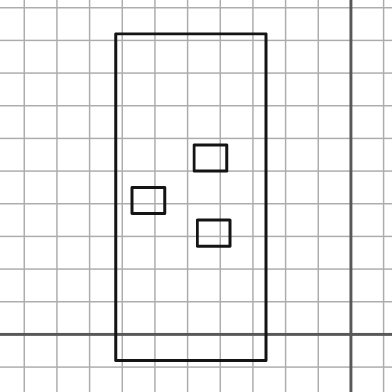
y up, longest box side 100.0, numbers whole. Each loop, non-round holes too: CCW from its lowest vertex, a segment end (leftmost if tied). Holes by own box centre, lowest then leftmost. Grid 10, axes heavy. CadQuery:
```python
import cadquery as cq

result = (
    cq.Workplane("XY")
    .moveTo(-72.0, -8.0)
    .lineTo(-26.0, -8.0)
    .lineTo(-26.0, 92.0)
    .lineTo(-72.0, 92.0)
    .close()
    .moveTo(-47.0, 27.0)
    .lineTo(-37.0, 27.0)
    .lineTo(-37.0, 35.0)
    .lineTo(-47.0, 35.0)
    .close()
    .moveTo(-67.0, 37.0)
    .lineTo(-57.0, 37.0)
    .lineTo(-57.0, 45.0)
    .lineTo(-67.0, 45.0)
    .close()
    .moveTo(-48.0, 50.0)
    .lineTo(-38.0, 50.0)
    .lineTo(-38.0, 58.0)
    .lineTo(-48.0, 58.0)
    .close()
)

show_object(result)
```